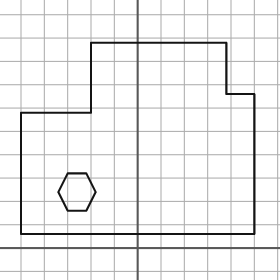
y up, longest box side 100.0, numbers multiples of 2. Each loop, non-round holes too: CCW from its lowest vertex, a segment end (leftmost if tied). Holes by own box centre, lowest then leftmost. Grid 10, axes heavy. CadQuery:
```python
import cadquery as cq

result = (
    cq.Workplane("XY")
    .moveTo(-50.0, 6.0)
    .lineTo(50.0, 6.0)
    .lineTo(50.0, 66.0)
    .lineTo(38.0, 66.0)
    .lineTo(38.0, 88.0)
    .lineTo(-20.0, 88.0)
    .lineTo(-20.0, 58.0)
    .lineTo(-50.0, 58.0)
    .close()
    .moveTo(-30.0, 16.0)
    .lineTo(-22.0, 16.0)
    .lineTo(-18.0, 24.0)
    .lineTo(-22.0, 32.0)
    .lineTo(-30.0, 32.0)
    .lineTo(-34.0, 24.0)
    .close()
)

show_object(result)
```